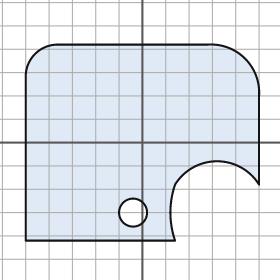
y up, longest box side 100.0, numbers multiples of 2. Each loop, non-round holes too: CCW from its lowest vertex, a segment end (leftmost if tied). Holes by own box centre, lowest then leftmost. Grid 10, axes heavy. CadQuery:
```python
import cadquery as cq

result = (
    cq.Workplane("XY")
    .moveTo(-50.0, -42.0)
    .lineTo(14.0, -42.0)
    .threePointArc((12.0, -30.0), (14.0, -18.0))
    .threePointArc((32.0, -8.0), (50.0, -18.0))
    .lineTo(50.0, 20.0)
    .threePointArc((44.0, 36.0), (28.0, 42.0))
    .lineTo(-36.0, 42.0)
    .threePointArc((-46.0, 38.0), (-50.0, 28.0))
    .close()
    .moveTo(-4.0, -30.0)
    .circle(6.0)
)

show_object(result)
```